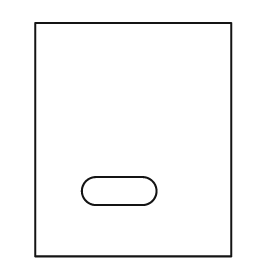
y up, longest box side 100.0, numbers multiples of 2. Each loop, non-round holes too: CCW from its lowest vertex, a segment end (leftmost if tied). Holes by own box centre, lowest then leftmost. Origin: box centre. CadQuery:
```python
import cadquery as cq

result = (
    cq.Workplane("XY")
    .moveTo(-42.0, -50.0)
    .lineTo(42.0, -50.0)
    .lineTo(42.0, 50.0)
    .lineTo(-42.0, 50.0)
    .close()
    .moveTo(-16.0, -28.0)
    .lineTo(4.0, -28.0)
    .threePointArc((10.0, -22.0), (4.0, -16.0))
    .lineTo(-16.0, -16.0)
    .threePointArc((-22.0, -22.0), (-16.0, -28.0))
    .close()
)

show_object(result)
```